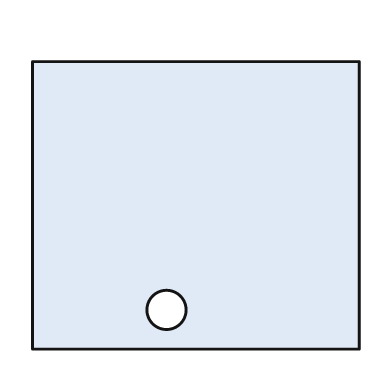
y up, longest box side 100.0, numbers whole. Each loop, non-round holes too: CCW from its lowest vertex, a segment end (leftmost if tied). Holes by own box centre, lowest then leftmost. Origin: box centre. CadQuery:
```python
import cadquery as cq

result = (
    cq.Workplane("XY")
    .moveTo(-50.0, -44.0)
    .lineTo(50.0, -44.0)
    .lineTo(50.0, 44.0)
    .lineTo(-50.0, 44.0)
    .close()
    .moveTo(-9.0, -32.0)
    .circle(6.0)
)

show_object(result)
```